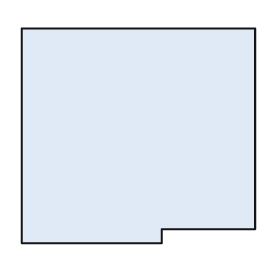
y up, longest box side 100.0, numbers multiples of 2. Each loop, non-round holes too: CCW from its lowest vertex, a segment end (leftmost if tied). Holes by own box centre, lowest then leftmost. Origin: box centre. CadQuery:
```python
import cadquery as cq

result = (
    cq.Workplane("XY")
    .moveTo(-50.0, -46.0)
    .lineTo(10.0, -46.0)
    .lineTo(10.0, -40.0)
    .lineTo(50.0, -40.0)
    .lineTo(50.0, 46.0)
    .lineTo(-50.0, 46.0)
    .close()
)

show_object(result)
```